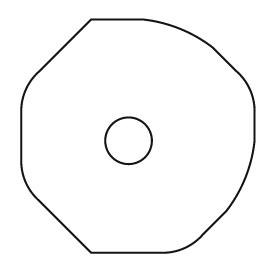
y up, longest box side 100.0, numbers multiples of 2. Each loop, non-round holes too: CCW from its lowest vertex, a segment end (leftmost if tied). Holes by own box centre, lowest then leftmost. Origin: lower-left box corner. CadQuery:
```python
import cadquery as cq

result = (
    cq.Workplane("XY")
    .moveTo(30.0, 0.0)
    .lineTo(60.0, 0.0)
    .threePointArc((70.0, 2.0), (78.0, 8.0))
    .lineTo(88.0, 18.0)
    .threePointArc((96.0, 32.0), (100.0, 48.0))
    .lineTo(100.0, 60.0)
    .threePointArc((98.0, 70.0), (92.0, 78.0))
    .lineTo(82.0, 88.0)
    .threePointArc((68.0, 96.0), (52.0, 100.0))
    .lineTo(30.0, 100.0)
    .lineTo(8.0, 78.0)
    .threePointArc((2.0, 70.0), (0.0, 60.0))
    .lineTo(0.0, 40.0)
    .threePointArc((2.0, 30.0), (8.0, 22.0))
    .close()
    .moveTo(46.0, 48.0)
    .circle(10.0)
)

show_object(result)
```